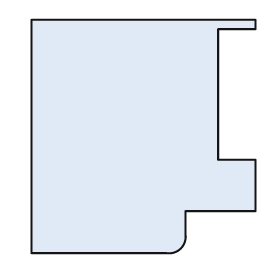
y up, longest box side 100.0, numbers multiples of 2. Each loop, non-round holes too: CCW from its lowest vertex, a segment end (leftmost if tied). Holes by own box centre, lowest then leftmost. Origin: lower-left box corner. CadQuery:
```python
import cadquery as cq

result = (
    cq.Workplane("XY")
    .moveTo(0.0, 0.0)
    .lineTo(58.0, 0.0)
    .threePointArc((64.0, 2.0), (66.0, 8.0))
    .lineTo(66.0, 18.0)
    .lineTo(96.0, 18.0)
    .lineTo(96.0, 40.0)
    .lineTo(80.0, 40.0)
    .lineTo(80.0, 96.0)
    .lineTo(96.0, 96.0)
    .lineTo(96.0, 100.0)
    .lineTo(0.0, 100.0)
    .close()
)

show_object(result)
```